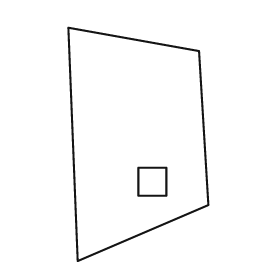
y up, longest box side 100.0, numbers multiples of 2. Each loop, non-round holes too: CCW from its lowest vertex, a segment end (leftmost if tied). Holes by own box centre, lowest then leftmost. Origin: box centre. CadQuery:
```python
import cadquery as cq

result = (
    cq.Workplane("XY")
    .moveTo(-26.0, -50.0)
    .lineTo(30.0, -26.0)
    .lineTo(26.0, 40.0)
    .lineTo(-30.0, 50.0)
    .close()
    .moveTo(0.0, -22.0)
    .lineTo(12.0, -22.0)
    .lineTo(12.0, -10.0)
    .lineTo(0.0, -10.0)
    .close()
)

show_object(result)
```